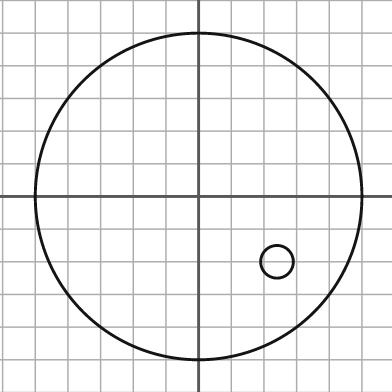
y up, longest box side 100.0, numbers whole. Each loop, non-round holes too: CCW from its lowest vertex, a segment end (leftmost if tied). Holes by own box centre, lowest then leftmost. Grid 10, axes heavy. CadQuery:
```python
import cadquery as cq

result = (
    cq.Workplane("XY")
    .moveTo(0.0, 0.0)
    .circle(50.0)
    .moveTo(24.0, -20.0)
    .circle(5.0)
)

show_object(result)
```